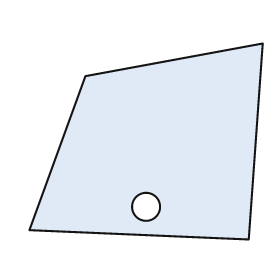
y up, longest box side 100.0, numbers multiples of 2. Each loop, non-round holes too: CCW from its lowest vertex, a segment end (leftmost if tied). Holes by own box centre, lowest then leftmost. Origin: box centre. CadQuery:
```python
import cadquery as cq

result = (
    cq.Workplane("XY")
    .moveTo(44.0, -42.0)
    .lineTo(50.0, 42.0)
    .lineTo(-26.0, 28.0)
    .lineTo(-50.0, -38.0)
    .close()
    .moveTo(0.0, -28.0)
    .circle(6.0)
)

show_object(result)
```